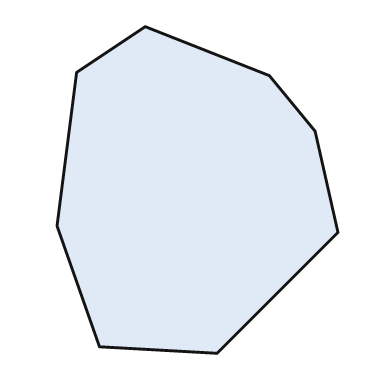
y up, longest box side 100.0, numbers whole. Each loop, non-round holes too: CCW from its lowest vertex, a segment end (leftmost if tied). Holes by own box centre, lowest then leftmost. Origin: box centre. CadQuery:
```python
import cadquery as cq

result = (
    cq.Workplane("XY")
    .moveTo(6.0, -50.0)
    .lineTo(43.0, -13.0)
    .lineTo(36.0, 18.0)
    .lineTo(22.0, 35.0)
    .lineTo(-16.0, 50.0)
    .lineTo(-37.0, 36.0)
    .lineTo(-43.0, -11.0)
    .lineTo(-30.0, -48.0)
    .close()
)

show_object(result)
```